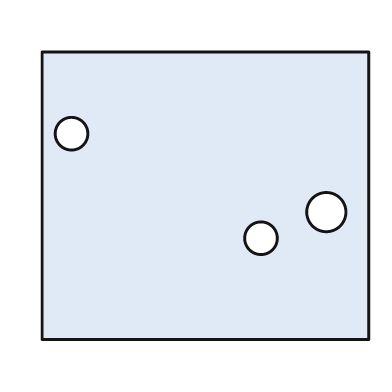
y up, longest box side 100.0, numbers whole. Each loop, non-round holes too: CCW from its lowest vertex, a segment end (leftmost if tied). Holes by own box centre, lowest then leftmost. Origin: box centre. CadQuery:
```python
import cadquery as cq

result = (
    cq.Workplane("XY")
    .moveTo(-50.0, -44.0)
    .lineTo(50.0, -44.0)
    .lineTo(50.0, 44.0)
    .lineTo(-50.0, 44.0)
    .close()
    .moveTo(17.0, -13.0)
    .circle(5.0)
    .moveTo(37.0, -5.0)
    .circle(6.0)
    .moveTo(-41.0, 19.0)
    .circle(5.0)
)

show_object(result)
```